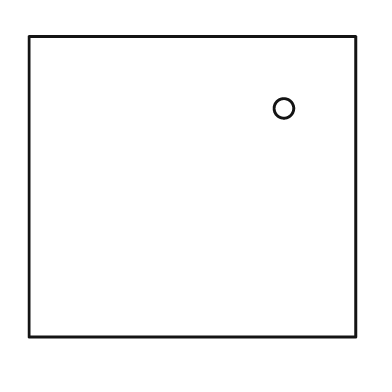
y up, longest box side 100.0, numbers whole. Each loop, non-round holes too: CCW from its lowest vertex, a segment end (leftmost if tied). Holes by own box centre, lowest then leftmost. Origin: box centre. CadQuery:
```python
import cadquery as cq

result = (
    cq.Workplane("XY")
    .moveTo(-50.0, -46.0)
    .lineTo(50.0, -46.0)
    .lineTo(50.0, 46.0)
    .lineTo(-50.0, 46.0)
    .close()
    .moveTo(28.0, 24.0)
    .circle(3.0)
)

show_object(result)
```